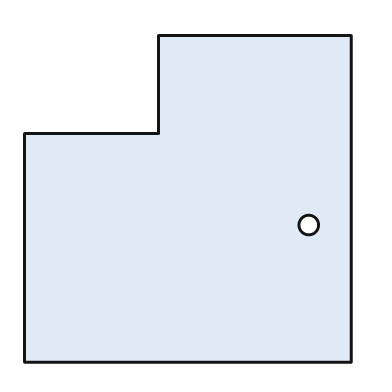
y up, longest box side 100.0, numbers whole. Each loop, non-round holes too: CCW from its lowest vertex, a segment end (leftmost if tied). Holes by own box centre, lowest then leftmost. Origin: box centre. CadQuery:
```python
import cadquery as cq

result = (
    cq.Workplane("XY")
    .moveTo(-50.0, -50.0)
    .lineTo(50.0, -50.0)
    .lineTo(50.0, 50.0)
    .lineTo(-9.0, 50.0)
    .lineTo(-9.0, 20.0)
    .lineTo(-50.0, 20.0)
    .close()
    .moveTo(37.0, -8.0)
    .circle(3.0)
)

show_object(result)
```